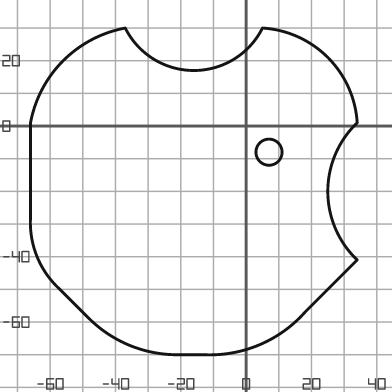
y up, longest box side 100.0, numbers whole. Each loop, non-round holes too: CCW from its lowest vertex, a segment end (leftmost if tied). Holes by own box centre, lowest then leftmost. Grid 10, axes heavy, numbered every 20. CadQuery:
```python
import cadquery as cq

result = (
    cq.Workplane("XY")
    .moveTo(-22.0, -70.0)
    .lineTo(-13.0, -70.0)
    .threePointArc((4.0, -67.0), (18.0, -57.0))
    .lineTo(34.0, -41.0)
    .threePointArc((25.0, -20.0), (34.0, 1.0))
    .threePointArc((25.0, 21.0), (5.0, 30.0))
    .threePointArc((-16.0, 17.0), (-37.0, 30.0))
    .threePointArc((-56.0, 20.0), (-66.0, 1.0))
    .lineTo(-66.0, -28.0)
    .threePointArc((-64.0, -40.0), (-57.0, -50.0))
    .lineTo(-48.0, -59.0)
    .threePointArc((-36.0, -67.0), (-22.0, -70.0))
    .close()
    .moveTo(7.0, -8.0)
    .circle(4.0)
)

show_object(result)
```